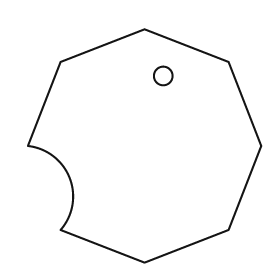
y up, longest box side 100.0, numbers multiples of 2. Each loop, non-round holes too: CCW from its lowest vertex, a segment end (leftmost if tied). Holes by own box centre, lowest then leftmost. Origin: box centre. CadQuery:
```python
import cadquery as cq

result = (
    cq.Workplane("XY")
    .moveTo(0.0, -50.0)
    .lineTo(36.0, -36.0)
    .lineTo(50.0, 0.0)
    .lineTo(36.0, 36.0)
    .lineTo(0.0, 50.0)
    .lineTo(-36.0, 36.0)
    .lineTo(-50.0, 0.0)
    .threePointArc((-32.0, -14.0), (-36.0, -36.0))
    .close()
    .moveTo(8.0, 30.0)
    .circle(4.0)
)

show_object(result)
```